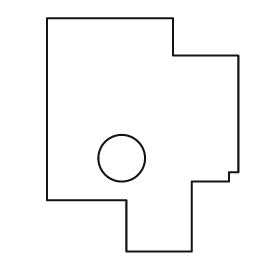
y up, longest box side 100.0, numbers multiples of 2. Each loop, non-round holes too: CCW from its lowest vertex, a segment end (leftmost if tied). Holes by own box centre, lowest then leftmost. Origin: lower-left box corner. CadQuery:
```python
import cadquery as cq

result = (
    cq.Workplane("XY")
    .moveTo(34.0, 0.0)
    .lineTo(62.0, 0.0)
    .lineTo(62.0, 30.0)
    .lineTo(78.0, 30.0)
    .lineTo(78.0, 34.0)
    .lineTo(82.0, 34.0)
    .lineTo(82.0, 84.0)
    .lineTo(54.0, 84.0)
    .lineTo(54.0, 100.0)
    .lineTo(0.0, 100.0)
    .lineTo(0.0, 22.0)
    .lineTo(34.0, 22.0)
    .close()
    .moveTo(32.0, 40.0)
    .circle(10.0)
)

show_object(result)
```